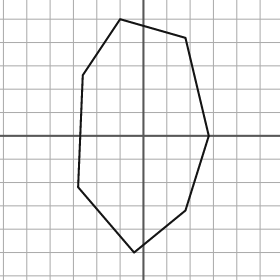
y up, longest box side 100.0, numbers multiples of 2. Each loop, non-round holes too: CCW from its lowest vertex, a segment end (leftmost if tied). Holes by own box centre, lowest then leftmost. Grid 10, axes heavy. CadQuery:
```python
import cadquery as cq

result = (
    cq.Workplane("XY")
    .moveTo(-4.0, -50.0)
    .lineTo(18.0, -32.0)
    .lineTo(28.0, 0.0)
    .lineTo(18.0, 42.0)
    .lineTo(-10.0, 50.0)
    .lineTo(-26.0, 26.0)
    .lineTo(-28.0, -22.0)
    .close()
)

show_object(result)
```